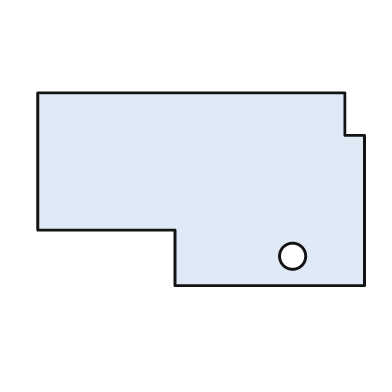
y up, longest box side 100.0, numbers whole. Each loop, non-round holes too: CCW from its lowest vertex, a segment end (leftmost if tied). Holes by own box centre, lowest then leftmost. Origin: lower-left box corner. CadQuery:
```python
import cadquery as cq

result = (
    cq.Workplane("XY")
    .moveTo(42.0, 0.0)
    .lineTo(100.0, 0.0)
    .lineTo(100.0, 46.0)
    .lineTo(94.0, 46.0)
    .lineTo(94.0, 59.0)
    .lineTo(0.0, 59.0)
    .lineTo(0.0, 17.0)
    .lineTo(42.0, 17.0)
    .close()
    .moveTo(78.0, 9.0)
    .circle(4.0)
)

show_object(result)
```